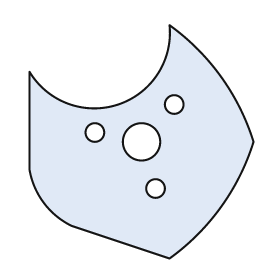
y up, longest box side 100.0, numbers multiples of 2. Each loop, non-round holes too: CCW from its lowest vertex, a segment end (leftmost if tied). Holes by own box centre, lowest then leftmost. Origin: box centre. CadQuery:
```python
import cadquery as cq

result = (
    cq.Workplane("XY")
    .moveTo(12.0, -50.0)
    .threePointArc((34.0, -28.0), (48.0, 0.0))
    .threePointArc((34.0, 28.0), (12.0, 50.0))
    .threePointArc((-10.0, 16.0), (-48.0, 30.0))
    .lineTo(-48.0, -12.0)
    .threePointArc((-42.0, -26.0), (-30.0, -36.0))
    .close()
    .moveTo(6.0, -20.0)
    .circle(4.0)
    .moveTo(0.0, 0.0)
    .circle(8.0)
    .moveTo(-20.0, 4.0)
    .circle(4.0)
    .moveTo(14.0, 16.0)
    .circle(4.0)
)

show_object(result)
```